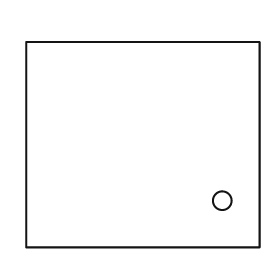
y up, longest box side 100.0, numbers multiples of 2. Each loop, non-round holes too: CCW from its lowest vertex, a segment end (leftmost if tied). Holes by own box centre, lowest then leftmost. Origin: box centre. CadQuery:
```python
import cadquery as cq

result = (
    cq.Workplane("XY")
    .moveTo(-50.0, -44.0)
    .lineTo(50.0, -44.0)
    .lineTo(50.0, 44.0)
    .lineTo(-50.0, 44.0)
    .close()
    .moveTo(34.0, -24.0)
    .circle(4.0)
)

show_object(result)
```